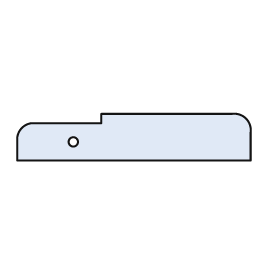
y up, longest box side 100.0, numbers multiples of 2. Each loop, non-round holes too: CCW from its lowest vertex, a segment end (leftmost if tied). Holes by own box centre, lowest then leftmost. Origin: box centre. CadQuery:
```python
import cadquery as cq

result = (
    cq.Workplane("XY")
    .moveTo(-50.0, -10.0)
    .lineTo(50.0, -10.0)
    .lineTo(50.0, 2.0)
    .threePointArc((48.0, 8.0), (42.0, 10.0))
    .lineTo(-14.0, 10.0)
    .lineTo(-14.0, 6.0)
    .lineTo(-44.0, 6.0)
    .threePointArc((-48.0, 4.0), (-50.0, 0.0))
    .close()
    .moveTo(-26.0, -2.0)
    .circle(2.0)
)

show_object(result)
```